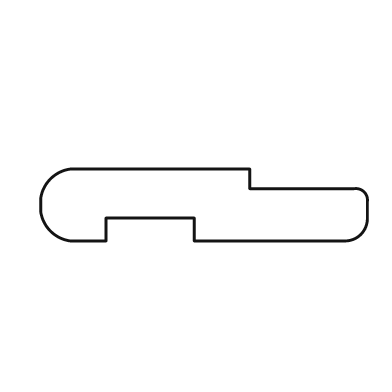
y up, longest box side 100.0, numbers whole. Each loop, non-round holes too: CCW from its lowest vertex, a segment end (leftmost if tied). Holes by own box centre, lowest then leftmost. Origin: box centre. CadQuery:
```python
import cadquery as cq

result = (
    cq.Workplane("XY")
    .moveTo(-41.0, -11.0)
    .lineTo(-30.0, -11.0)
    .lineTo(-30.0, -4.0)
    .lineTo(-3.0, -4.0)
    .lineTo(-3.0, -11.0)
    .lineTo(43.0, -11.0)
    .threePointArc((48.0, -9.0), (50.0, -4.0))
    .lineTo(50.0, 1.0)
    .threePointArc((49.0, 4.0), (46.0, 5.0))
    .lineTo(14.0, 5.0)
    .lineTo(14.0, 11.0)
    .lineTo(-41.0, 11.0)
    .threePointArc((-47.0, 8.0), (-50.0, 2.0))
    .lineTo(-50.0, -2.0)
    .threePointArc((-47.0, -8.0), (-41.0, -11.0))
    .close()
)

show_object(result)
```